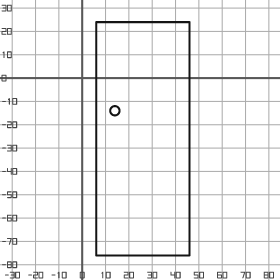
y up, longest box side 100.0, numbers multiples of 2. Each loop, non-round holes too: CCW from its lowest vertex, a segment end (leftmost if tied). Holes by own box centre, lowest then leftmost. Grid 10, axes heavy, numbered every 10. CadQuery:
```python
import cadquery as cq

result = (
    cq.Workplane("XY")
    .moveTo(6.0, -76.0)
    .lineTo(46.0, -76.0)
    .lineTo(46.0, 24.0)
    .lineTo(6.0, 24.0)
    .close()
    .moveTo(14.0, -14.0)
    .circle(2.0)
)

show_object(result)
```